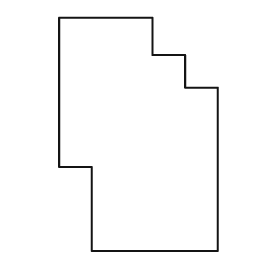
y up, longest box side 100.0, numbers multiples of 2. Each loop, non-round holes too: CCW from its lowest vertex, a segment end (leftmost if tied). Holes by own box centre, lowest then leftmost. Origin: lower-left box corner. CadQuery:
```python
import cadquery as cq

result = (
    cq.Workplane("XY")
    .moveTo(14.0, 0.0)
    .lineTo(68.0, 0.0)
    .lineTo(68.0, 70.0)
    .lineTo(54.0, 70.0)
    .lineTo(54.0, 84.0)
    .lineTo(40.0, 84.0)
    .lineTo(40.0, 100.0)
    .lineTo(0.0, 100.0)
    .lineTo(0.0, 36.0)
    .lineTo(14.0, 36.0)
    .close()
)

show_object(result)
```